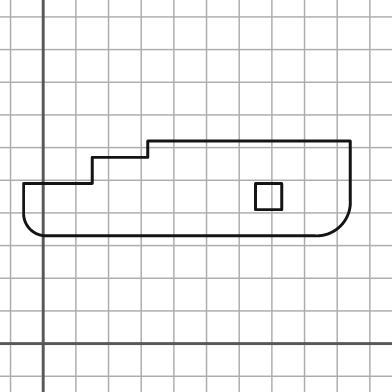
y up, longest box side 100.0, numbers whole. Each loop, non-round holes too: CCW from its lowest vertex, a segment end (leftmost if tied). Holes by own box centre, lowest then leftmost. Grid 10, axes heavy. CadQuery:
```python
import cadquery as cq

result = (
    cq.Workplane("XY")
    .moveTo(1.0, 33.0)
    .lineTo(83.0, 33.0)
    .threePointArc((91.0, 36.0), (94.0, 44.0))
    .lineTo(94.0, 62.0)
    .lineTo(32.0, 62.0)
    .lineTo(32.0, 57.0)
    .lineTo(15.0, 57.0)
    .lineTo(15.0, 49.0)
    .lineTo(-6.0, 49.0)
    .lineTo(-6.0, 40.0)
    .threePointArc((-4.0, 35.0), (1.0, 33.0))
    .close()
    .moveTo(65.0, 41.0)
    .lineTo(73.0, 41.0)
    .lineTo(73.0, 49.0)
    .lineTo(65.0, 49.0)
    .close()
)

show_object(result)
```